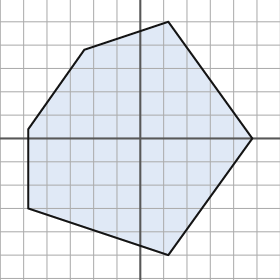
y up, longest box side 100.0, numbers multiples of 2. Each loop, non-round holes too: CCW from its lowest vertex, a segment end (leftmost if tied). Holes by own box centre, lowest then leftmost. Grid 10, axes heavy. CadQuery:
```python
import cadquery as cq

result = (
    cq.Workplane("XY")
    .moveTo(12.0, -50.0)
    .lineTo(48.0, 0.0)
    .lineTo(12.0, 50.0)
    .lineTo(-24.0, 38.0)
    .lineTo(-48.0, 4.0)
    .lineTo(-48.0, -30.0)
    .close()
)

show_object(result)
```